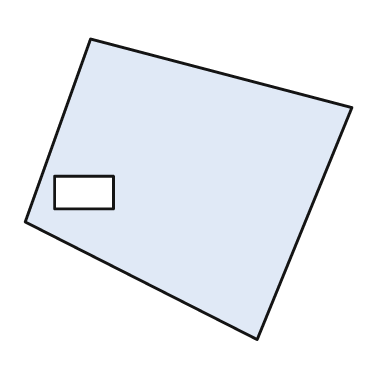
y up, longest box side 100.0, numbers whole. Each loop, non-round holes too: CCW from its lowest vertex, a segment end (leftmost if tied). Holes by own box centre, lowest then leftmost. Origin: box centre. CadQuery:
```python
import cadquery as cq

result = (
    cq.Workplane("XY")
    .moveTo(21.0, -46.0)
    .lineTo(50.0, 25.0)
    .lineTo(-30.0, 46.0)
    .lineTo(-50.0, -10.0)
    .close()
    .moveTo(-41.0, -6.0)
    .lineTo(-23.0, -6.0)
    .lineTo(-23.0, 4.0)
    .lineTo(-41.0, 4.0)
    .close()
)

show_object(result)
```